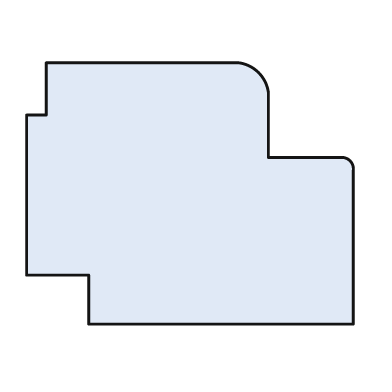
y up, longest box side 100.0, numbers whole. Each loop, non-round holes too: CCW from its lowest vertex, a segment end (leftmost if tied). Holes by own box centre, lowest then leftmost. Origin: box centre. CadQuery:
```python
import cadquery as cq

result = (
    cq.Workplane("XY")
    .moveTo(-31.0, -40.0)
    .lineTo(50.0, -40.0)
    .lineTo(50.0, 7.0)
    .threePointArc((49.0, 10.0), (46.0, 11.0))
    .lineTo(24.0, 11.0)
    .lineTo(24.0, 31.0)
    .threePointArc((21.0, 37.0), (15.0, 40.0))
    .lineTo(-44.0, 40.0)
    .lineTo(-44.0, 24.0)
    .lineTo(-50.0, 24.0)
    .lineTo(-50.0, -25.0)
    .lineTo(-31.0, -25.0)
    .close()
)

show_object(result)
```